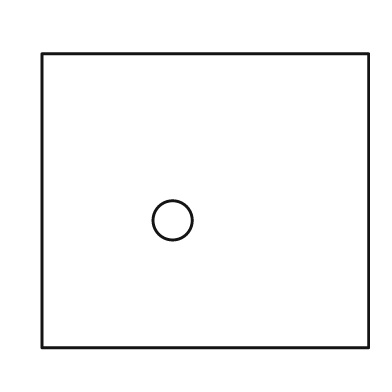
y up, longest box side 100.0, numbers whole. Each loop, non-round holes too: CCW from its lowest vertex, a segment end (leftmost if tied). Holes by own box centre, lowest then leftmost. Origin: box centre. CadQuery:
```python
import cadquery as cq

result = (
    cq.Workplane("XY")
    .moveTo(-50.0, -45.0)
    .lineTo(50.0, -45.0)
    .lineTo(50.0, 45.0)
    .lineTo(-50.0, 45.0)
    .close()
    .moveTo(-10.0, -6.0)
    .circle(6.0)
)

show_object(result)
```